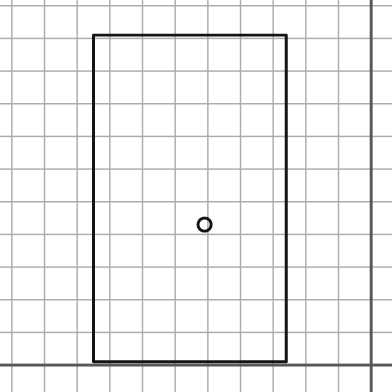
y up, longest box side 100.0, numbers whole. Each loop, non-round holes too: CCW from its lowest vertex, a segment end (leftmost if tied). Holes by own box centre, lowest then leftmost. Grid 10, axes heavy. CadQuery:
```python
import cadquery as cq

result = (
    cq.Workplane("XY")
    .moveTo(-85.0, 1.0)
    .lineTo(-26.0, 1.0)
    .lineTo(-26.0, 101.0)
    .lineTo(-85.0, 101.0)
    .close()
    .moveTo(-51.0, 43.0)
    .circle(2.0)
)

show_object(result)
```